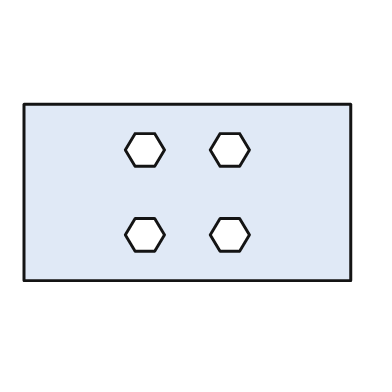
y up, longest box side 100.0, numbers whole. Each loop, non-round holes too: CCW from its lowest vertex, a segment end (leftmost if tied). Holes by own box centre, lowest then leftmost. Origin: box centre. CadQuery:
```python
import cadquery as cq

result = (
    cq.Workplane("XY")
    .moveTo(-50.0, -27.0)
    .lineTo(50.0, -27.0)
    .lineTo(50.0, 27.0)
    .lineTo(-50.0, 27.0)
    .close()
    .moveTo(-16.0, -18.0)
    .lineTo(-10.0, -18.0)
    .lineTo(-7.0, -13.0)
    .lineTo(-10.0, -8.0)
    .lineTo(-16.0, -8.0)
    .lineTo(-19.0, -13.0)
    .close()
    .moveTo(10.0, -18.0)
    .lineTo(16.0, -18.0)
    .lineTo(19.0, -13.0)
    .lineTo(16.0, -8.0)
    .lineTo(10.0, -8.0)
    .lineTo(7.0, -13.0)
    .close()
    .moveTo(-16.0, 8.0)
    .lineTo(-10.0, 8.0)
    .lineTo(-7.0, 13.0)
    .lineTo(-10.0, 18.0)
    .lineTo(-16.0, 18.0)
    .lineTo(-19.0, 13.0)
    .close()
    .moveTo(10.0, 8.0)
    .lineTo(16.0, 8.0)
    .lineTo(19.0, 13.0)
    .lineTo(16.0, 18.0)
    .lineTo(10.0, 18.0)
    .lineTo(7.0, 13.0)
    .close()
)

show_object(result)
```